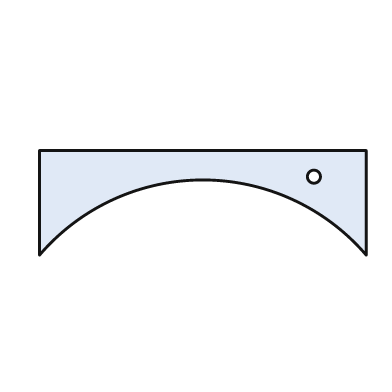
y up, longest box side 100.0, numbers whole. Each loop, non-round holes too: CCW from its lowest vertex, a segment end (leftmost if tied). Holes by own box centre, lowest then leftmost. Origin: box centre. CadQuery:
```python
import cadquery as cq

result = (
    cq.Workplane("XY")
    .moveTo(-50.0, -16.0)
    .threePointArc((0.0, 7.0), (50.0, -16.0))
    .lineTo(50.0, 16.0)
    .lineTo(-50.0, 16.0)
    .close()
    .moveTo(34.0, 8.0)
    .circle(2.0)
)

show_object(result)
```